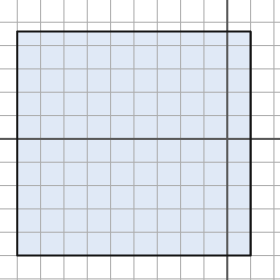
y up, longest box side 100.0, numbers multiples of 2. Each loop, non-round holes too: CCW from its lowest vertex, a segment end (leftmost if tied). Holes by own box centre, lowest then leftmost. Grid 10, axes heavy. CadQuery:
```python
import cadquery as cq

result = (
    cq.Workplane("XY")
    .moveTo(-90.0, -50.0)
    .lineTo(10.0, -50.0)
    .lineTo(10.0, 46.0)
    .lineTo(-90.0, 46.0)
    .close()
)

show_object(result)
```